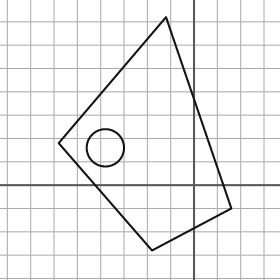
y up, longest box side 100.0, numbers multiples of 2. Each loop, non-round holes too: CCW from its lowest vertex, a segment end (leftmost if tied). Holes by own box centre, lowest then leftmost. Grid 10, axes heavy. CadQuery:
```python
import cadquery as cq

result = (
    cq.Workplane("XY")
    .moveTo(-18.0, -28.0)
    .lineTo(16.0, -10.0)
    .lineTo(-12.0, 72.0)
    .lineTo(-58.0, 18.0)
    .close()
    .moveTo(-38.0, 16.0)
    .circle(8.0)
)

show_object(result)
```